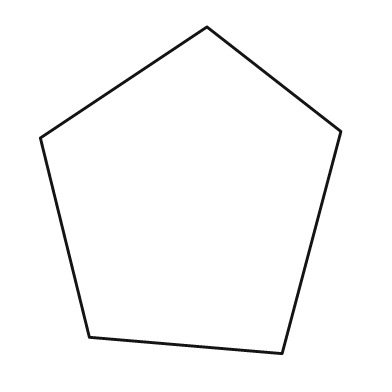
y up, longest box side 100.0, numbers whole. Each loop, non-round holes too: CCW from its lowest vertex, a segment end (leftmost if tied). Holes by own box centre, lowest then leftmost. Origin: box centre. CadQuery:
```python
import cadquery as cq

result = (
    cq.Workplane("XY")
    .moveTo(28.0, -50.0)
    .lineTo(46.0, 18.0)
    .lineTo(5.0, 50.0)
    .lineTo(-46.0, 16.0)
    .lineTo(-31.0, -45.0)
    .close()
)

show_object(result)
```